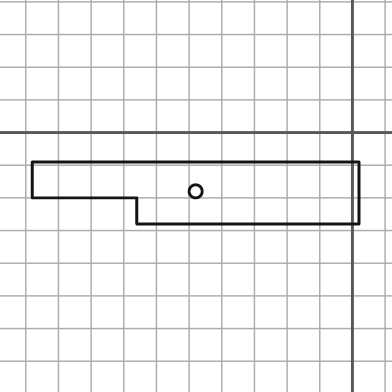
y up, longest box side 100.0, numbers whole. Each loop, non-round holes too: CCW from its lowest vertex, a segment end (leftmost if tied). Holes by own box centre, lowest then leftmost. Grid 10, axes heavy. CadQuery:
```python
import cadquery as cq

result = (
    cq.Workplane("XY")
    .moveTo(-66.0, -28.0)
    .lineTo(2.0, -28.0)
    .lineTo(2.0, -9.0)
    .lineTo(-98.0, -9.0)
    .lineTo(-98.0, -20.0)
    .lineTo(-66.0, -20.0)
    .close()
    .moveTo(-48.0, -18.0)
    .circle(2.0)
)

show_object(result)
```